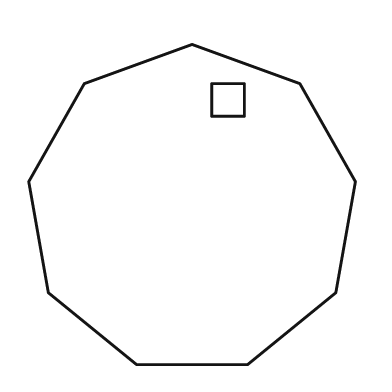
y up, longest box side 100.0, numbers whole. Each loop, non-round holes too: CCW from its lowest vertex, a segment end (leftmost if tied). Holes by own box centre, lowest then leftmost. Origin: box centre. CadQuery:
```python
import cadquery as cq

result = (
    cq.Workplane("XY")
    .moveTo(-17.0, -49.0)
    .lineTo(17.0, -49.0)
    .lineTo(44.0, -27.0)
    .lineTo(50.0, 7.0)
    .lineTo(33.0, 37.0)
    .lineTo(0.0, 49.0)
    .lineTo(-33.0, 37.0)
    .lineTo(-50.0, 7.0)
    .lineTo(-44.0, -27.0)
    .close()
    .moveTo(6.0, 27.0)
    .lineTo(16.0, 27.0)
    .lineTo(16.0, 37.0)
    .lineTo(6.0, 37.0)
    .close()
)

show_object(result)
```